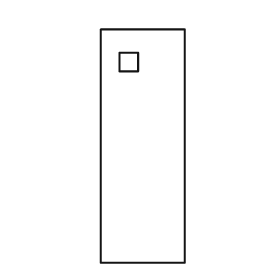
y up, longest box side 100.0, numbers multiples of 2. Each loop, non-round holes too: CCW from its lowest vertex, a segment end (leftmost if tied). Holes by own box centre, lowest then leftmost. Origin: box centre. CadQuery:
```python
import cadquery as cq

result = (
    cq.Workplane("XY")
    .moveTo(-18.0, -50.0)
    .lineTo(18.0, -50.0)
    .lineTo(18.0, 50.0)
    .lineTo(-18.0, 50.0)
    .close()
    .moveTo(-10.0, 32.0)
    .lineTo(-2.0, 32.0)
    .lineTo(-2.0, 40.0)
    .lineTo(-10.0, 40.0)
    .close()
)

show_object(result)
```